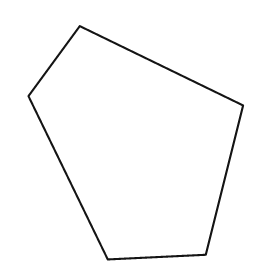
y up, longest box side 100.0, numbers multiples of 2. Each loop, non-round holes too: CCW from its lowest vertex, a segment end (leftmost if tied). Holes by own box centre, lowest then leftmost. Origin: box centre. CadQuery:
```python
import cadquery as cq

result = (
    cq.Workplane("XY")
    .moveTo(-12.0, -50.0)
    .lineTo(30.0, -48.0)
    .lineTo(46.0, 16.0)
    .lineTo(-24.0, 50.0)
    .lineTo(-46.0, 20.0)
    .close()
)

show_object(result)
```